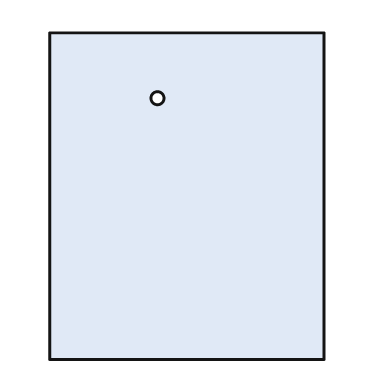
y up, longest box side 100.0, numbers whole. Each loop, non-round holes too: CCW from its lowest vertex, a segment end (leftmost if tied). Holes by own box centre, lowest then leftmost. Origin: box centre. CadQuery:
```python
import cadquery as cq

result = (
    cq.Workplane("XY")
    .moveTo(-42.0, -50.0)
    .lineTo(42.0, -50.0)
    .lineTo(42.0, 50.0)
    .lineTo(-42.0, 50.0)
    .close()
    .moveTo(-9.0, 30.0)
    .circle(2.0)
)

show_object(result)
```